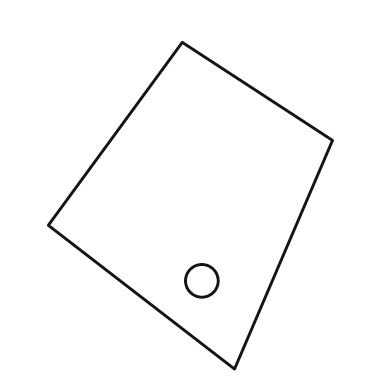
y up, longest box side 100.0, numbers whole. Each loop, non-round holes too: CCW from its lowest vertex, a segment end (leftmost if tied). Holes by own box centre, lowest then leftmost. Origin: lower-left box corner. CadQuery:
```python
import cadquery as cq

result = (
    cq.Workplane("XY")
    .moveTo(57.0, 0.0)
    .lineTo(87.0, 70.0)
    .lineTo(41.0, 100.0)
    .lineTo(0.0, 44.0)
    .close()
    .moveTo(47.0, 27.0)
    .circle(5.0)
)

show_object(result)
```